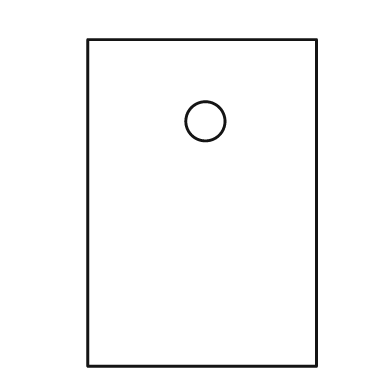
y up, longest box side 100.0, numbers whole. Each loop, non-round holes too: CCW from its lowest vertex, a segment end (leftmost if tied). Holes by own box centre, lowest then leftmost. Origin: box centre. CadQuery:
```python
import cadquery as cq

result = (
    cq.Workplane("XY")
    .moveTo(-35.0, -50.0)
    .lineTo(35.0, -50.0)
    .lineTo(35.0, 50.0)
    .lineTo(-35.0, 50.0)
    .close()
    .moveTo(1.0, 25.0)
    .circle(6.0)
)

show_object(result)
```